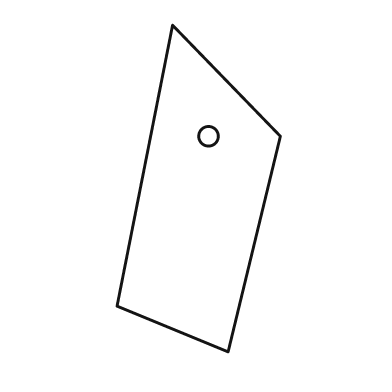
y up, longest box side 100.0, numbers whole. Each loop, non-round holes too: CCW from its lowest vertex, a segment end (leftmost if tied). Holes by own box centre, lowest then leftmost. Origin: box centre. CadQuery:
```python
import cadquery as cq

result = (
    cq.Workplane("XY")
    .moveTo(9.0, -50.0)
    .lineTo(25.0, 16.0)
    .lineTo(-8.0, 50.0)
    .lineTo(-25.0, -36.0)
    .close()
    .moveTo(3.0, 16.0)
    .circle(3.0)
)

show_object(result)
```